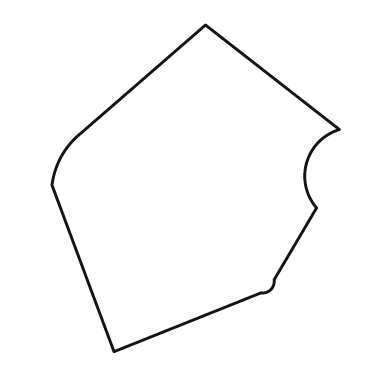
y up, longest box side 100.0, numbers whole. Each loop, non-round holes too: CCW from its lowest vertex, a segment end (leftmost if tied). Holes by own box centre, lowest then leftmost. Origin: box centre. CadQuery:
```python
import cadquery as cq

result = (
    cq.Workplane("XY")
    .moveTo(-25.0, -50.0)
    .lineTo(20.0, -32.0)
    .threePointArc((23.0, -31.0), (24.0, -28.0))
    .lineTo(37.0, -6.0)
    .threePointArc((34.0, 8.0), (44.0, 18.0))
    .lineTo(3.0, 50.0)
    .lineTo(-35.0, 17.0)
    .threePointArc((-41.0, 10.0), (-44.0, 1.0))
    .close()
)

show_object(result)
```